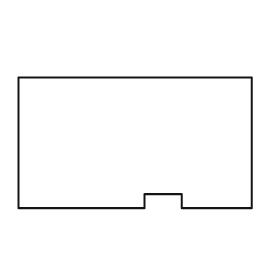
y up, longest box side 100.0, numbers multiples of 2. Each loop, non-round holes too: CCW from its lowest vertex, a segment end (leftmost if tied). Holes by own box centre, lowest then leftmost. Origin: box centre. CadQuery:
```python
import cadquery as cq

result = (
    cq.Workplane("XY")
    .moveTo(-50.0, -28.0)
    .lineTo(4.0, -28.0)
    .lineTo(4.0, -22.0)
    .lineTo(20.0, -22.0)
    .lineTo(20.0, -28.0)
    .lineTo(50.0, -28.0)
    .lineTo(50.0, 28.0)
    .lineTo(-50.0, 28.0)
    .close()
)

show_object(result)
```